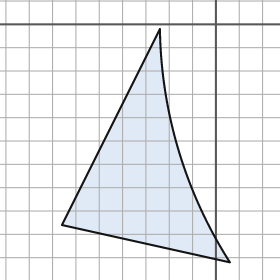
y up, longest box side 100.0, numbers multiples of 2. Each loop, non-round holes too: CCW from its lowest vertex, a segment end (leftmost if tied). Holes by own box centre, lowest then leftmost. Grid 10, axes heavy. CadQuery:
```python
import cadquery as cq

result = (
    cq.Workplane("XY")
    .moveTo(6.0, -102.0)
    .threePointArc((-16.0, -54.0), (-24.0, -2.0))
    .lineTo(-66.0, -86.0)
    .close()
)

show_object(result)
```